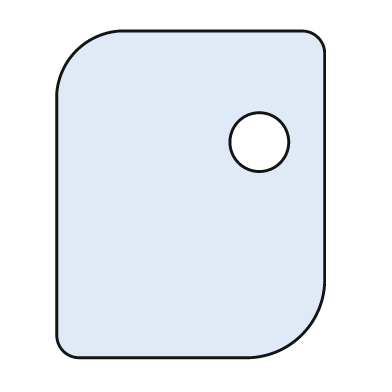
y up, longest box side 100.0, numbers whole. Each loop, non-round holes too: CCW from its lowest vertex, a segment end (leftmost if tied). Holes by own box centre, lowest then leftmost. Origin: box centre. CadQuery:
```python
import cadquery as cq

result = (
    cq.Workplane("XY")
    .moveTo(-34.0, -50.0)
    .lineTo(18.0, -50.0)
    .threePointArc((34.0, -43.0), (41.0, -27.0))
    .lineTo(41.0, 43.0)
    .threePointArc((39.0, 48.0), (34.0, 50.0))
    .lineTo(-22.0, 50.0)
    .threePointArc((-35.0, 44.0), (-41.0, 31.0))
    .lineTo(-41.0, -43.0)
    .threePointArc((-39.0, -48.0), (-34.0, -50.0))
    .close()
    .moveTo(21.0, 16.0)
    .circle(9.0)
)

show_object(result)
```